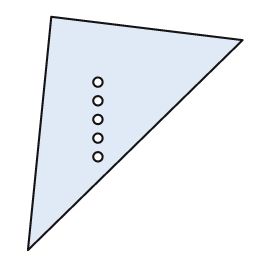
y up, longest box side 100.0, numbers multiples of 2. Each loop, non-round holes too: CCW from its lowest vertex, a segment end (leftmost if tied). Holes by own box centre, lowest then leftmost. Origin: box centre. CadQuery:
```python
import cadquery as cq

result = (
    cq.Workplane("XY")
    .moveTo(-46.0, -50.0)
    .lineTo(46.0, 40.0)
    .lineTo(-36.0, 50.0)
    .close()
    .moveTo(-16.0, -10.0)
    .circle(2.0)
    .moveTo(-16.0, -2.0)
    .circle(2.0)
    .moveTo(-16.0, 6.0)
    .circle(2.0)
    .moveTo(-16.0, 14.0)
    .circle(2.0)
    .moveTo(-16.0, 22.0)
    .circle(2.0)
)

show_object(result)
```